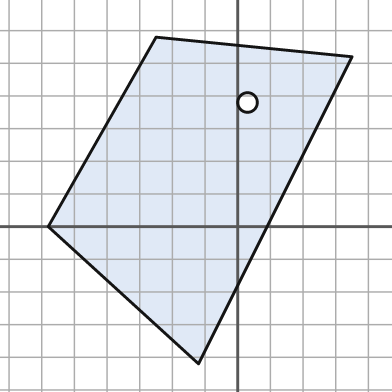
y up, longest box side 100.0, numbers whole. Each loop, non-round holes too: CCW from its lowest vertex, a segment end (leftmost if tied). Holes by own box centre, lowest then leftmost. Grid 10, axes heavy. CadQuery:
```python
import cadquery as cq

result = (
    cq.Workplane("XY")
    .moveTo(-12.0, -42.0)
    .lineTo(35.0, 52.0)
    .lineTo(-25.0, 58.0)
    .lineTo(-58.0, 0.0)
    .close()
    .moveTo(3.0, 38.0)
    .circle(3.0)
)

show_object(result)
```